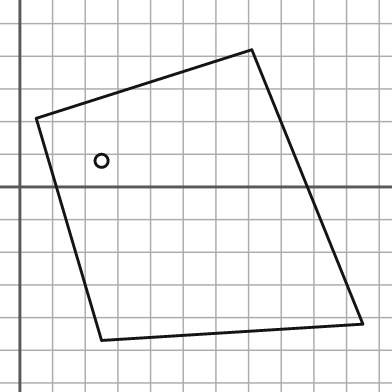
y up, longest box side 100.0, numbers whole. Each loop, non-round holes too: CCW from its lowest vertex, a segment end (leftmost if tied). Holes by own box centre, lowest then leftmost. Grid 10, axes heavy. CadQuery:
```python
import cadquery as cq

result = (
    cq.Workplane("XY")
    .moveTo(25.0, -47.0)
    .lineTo(105.0, -42.0)
    .lineTo(71.0, 42.0)
    .lineTo(5.0, 21.0)
    .close()
    .moveTo(25.0, 8.0)
    .circle(2.0)
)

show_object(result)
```